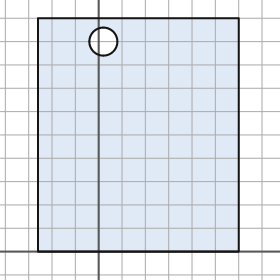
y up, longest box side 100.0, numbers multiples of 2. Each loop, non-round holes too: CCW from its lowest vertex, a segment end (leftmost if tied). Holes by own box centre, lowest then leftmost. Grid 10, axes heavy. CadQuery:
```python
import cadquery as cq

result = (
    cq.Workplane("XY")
    .moveTo(-26.0, 0.0)
    .lineTo(60.0, 0.0)
    .lineTo(60.0, 100.0)
    .lineTo(-26.0, 100.0)
    .close()
    .moveTo(2.0, 90.0)
    .circle(6.0)
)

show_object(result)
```